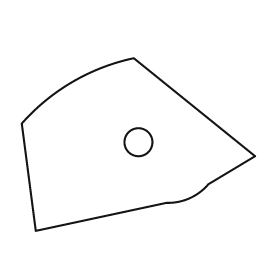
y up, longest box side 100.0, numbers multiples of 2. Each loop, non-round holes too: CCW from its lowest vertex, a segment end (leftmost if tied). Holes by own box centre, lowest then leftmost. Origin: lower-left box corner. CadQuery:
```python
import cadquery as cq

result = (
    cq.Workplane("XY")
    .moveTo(6.0, 0.0)
    .lineTo(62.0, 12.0)
    .threePointArc((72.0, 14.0), (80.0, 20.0))
    .lineTo(100.0, 32.0)
    .lineTo(48.0, 74.0)
    .threePointArc((22.0, 64.0), (0.0, 46.0))
    .close()
    .moveTo(50.0, 38.0)
    .circle(6.0)
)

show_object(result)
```